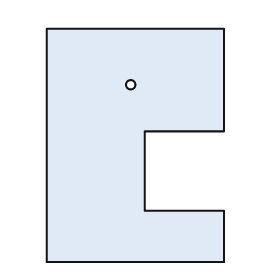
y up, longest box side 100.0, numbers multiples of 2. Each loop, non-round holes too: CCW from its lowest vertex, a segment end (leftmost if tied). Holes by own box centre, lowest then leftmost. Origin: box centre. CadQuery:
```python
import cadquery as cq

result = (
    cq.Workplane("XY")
    .moveTo(-38.0, -50.0)
    .lineTo(38.0, -50.0)
    .lineTo(38.0, -28.0)
    .lineTo(4.0, -28.0)
    .lineTo(4.0, 6.0)
    .lineTo(38.0, 6.0)
    .lineTo(38.0, 50.0)
    .lineTo(-38.0, 50.0)
    .close()
    .moveTo(-2.0, 26.0)
    .circle(2.0)
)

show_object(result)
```